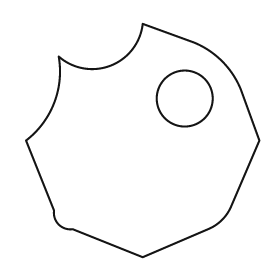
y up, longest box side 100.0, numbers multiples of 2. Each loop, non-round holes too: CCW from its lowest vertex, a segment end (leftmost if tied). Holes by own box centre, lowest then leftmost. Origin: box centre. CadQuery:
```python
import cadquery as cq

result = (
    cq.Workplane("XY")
    .moveTo(0.0, -50.0)
    .lineTo(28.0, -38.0)
    .threePointArc((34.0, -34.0), (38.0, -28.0))
    .lineTo(50.0, 0.0)
    .lineTo(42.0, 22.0)
    .threePointArc((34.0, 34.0), (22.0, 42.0))
    .lineTo(0.0, 50.0)
    .threePointArc((-14.0, 32.0), (-36.0, 36.0))
    .threePointArc((-38.0, 16.0), (-50.0, 0.0))
    .lineTo(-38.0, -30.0)
    .threePointArc((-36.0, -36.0), (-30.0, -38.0))
    .close()
    .moveTo(18.0, 18.0)
    .circle(12.0)
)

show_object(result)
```